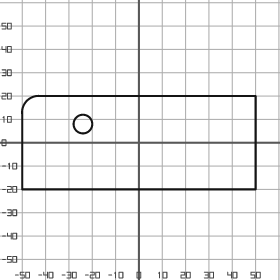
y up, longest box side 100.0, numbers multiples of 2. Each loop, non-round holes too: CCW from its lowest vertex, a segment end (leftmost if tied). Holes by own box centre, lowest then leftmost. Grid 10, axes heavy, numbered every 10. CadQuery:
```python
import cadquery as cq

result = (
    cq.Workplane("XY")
    .moveTo(-50.0, -20.0)
    .lineTo(50.0, -20.0)
    .lineTo(50.0, 20.0)
    .lineTo(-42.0, 20.0)
    .threePointArc((-48.0, 18.0), (-50.0, 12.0))
    .close()
    .moveTo(-24.0, 8.0)
    .circle(4.0)
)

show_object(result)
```